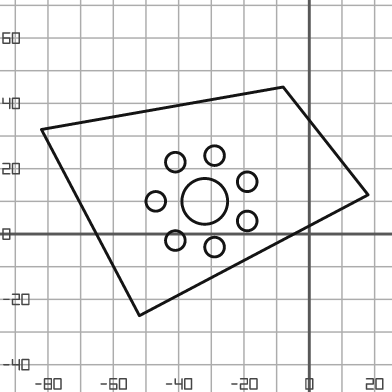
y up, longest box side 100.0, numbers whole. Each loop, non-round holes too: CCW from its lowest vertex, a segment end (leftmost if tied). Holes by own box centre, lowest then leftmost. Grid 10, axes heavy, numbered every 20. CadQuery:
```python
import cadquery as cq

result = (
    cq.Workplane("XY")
    .moveTo(-52.0, -25.0)
    .lineTo(18.0, 12.0)
    .lineTo(-8.0, 45.0)
    .lineTo(-82.0, 32.0)
    .close()
    .moveTo(-29.0, -4.0)
    .circle(3.0)
    .moveTo(-41.0, -2.0)
    .circle(3.0)
    .moveTo(-19.0, 4.0)
    .circle(3.0)
    .moveTo(-47.0, 10.0)
    .circle(3.0)
    .moveTo(-32.0, 10.0)
    .circle(7.0)
    .moveTo(-19.0, 16.0)
    .circle(3.0)
    .moveTo(-41.0, 22.0)
    .circle(3.0)
    .moveTo(-29.0, 24.0)
    .circle(3.0)
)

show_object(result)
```